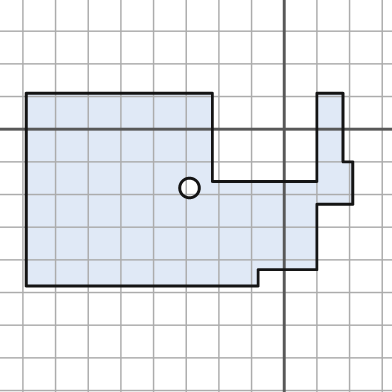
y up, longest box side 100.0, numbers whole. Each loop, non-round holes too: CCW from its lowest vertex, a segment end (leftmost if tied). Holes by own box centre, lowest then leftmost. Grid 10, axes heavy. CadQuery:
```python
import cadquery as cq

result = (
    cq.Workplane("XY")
    .moveTo(-79.0, -48.0)
    .lineTo(-8.0, -48.0)
    .lineTo(-8.0, -43.0)
    .lineTo(10.0, -43.0)
    .lineTo(10.0, -23.0)
    .lineTo(21.0, -23.0)
    .lineTo(21.0, -10.0)
    .lineTo(18.0, -10.0)
    .lineTo(18.0, 11.0)
    .lineTo(10.0, 11.0)
    .lineTo(10.0, -16.0)
    .lineTo(-22.0, -16.0)
    .lineTo(-22.0, 11.0)
    .lineTo(-79.0, 11.0)
    .close()
    .moveTo(-29.0, -18.0)
    .circle(3.0)
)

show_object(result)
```